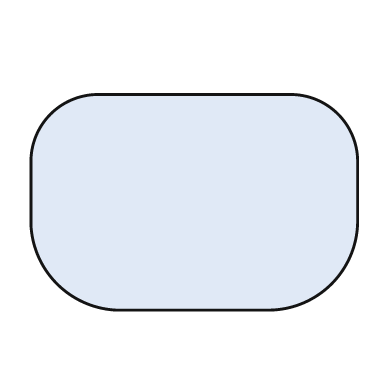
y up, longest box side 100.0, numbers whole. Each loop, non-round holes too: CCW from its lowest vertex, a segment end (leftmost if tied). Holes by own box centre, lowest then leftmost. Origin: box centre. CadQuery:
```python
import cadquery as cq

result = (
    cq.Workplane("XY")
    .moveTo(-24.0, -33.0)
    .lineTo(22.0, -33.0)
    .threePointArc((42.0, -25.0), (50.0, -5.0))
    .lineTo(50.0, 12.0)
    .threePointArc((44.0, 27.0), (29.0, 33.0))
    .lineTo(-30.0, 33.0)
    .threePointArc((-44.0, 27.0), (-50.0, 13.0))
    .lineTo(-50.0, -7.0)
    .threePointArc((-42.0, -25.0), (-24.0, -33.0))
    .close()
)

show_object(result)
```